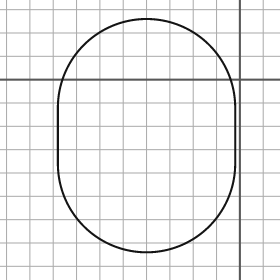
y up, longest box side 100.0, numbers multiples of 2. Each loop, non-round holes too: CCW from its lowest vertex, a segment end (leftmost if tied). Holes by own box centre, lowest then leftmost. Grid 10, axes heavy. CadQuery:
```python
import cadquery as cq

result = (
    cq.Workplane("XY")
    .moveTo(-78.0, -36.0)
    .threePointArc((-40.0, -74.0), (-2.0, -36.0))
    .lineTo(-2.0, -12.0)
    .threePointArc((-40.0, 26.0), (-78.0, -12.0))
    .close()
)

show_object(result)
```